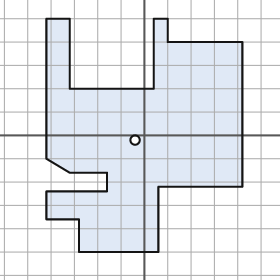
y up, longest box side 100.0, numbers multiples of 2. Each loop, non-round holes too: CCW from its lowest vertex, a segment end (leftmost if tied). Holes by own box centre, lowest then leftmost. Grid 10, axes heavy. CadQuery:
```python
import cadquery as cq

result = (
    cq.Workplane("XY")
    .moveTo(-28.0, -50.0)
    .lineTo(6.0, -50.0)
    .lineTo(6.0, -22.0)
    .lineTo(42.0, -22.0)
    .lineTo(42.0, 40.0)
    .lineTo(10.0, 40.0)
    .lineTo(10.0, 50.0)
    .lineTo(4.0, 50.0)
    .lineTo(4.0, 20.0)
    .lineTo(-32.0, 20.0)
    .lineTo(-32.0, 50.0)
    .lineTo(-42.0, 50.0)
    .lineTo(-42.0, -10.0)
    .lineTo(-32.0, -16.0)
    .lineTo(-16.0, -16.0)
    .lineTo(-16.0, -24.0)
    .lineTo(-42.0, -24.0)
    .lineTo(-42.0, -36.0)
    .lineTo(-28.0, -36.0)
    .close()
    .moveTo(-4.0, -2.0)
    .circle(2.0)
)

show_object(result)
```